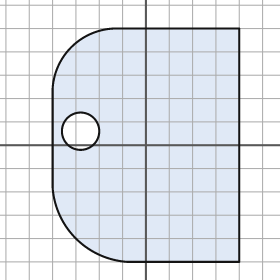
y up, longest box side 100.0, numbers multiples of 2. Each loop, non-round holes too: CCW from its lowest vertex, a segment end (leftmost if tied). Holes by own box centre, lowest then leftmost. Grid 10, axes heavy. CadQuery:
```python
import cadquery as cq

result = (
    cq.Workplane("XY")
    .moveTo(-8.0, -50.0)
    .lineTo(40.0, -50.0)
    .lineTo(40.0, 50.0)
    .lineTo(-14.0, 50.0)
    .threePointArc((-32.0, 42.0), (-40.0, 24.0))
    .lineTo(-40.0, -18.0)
    .threePointArc((-30.0, -40.0), (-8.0, -50.0))
    .close()
    .moveTo(-28.0, 6.0)
    .circle(8.0)
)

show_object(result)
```